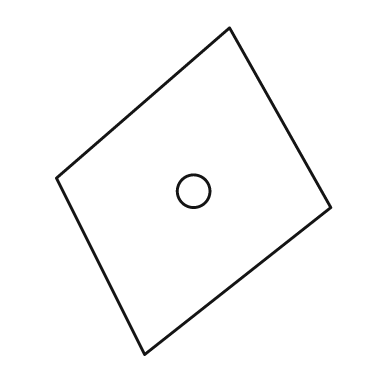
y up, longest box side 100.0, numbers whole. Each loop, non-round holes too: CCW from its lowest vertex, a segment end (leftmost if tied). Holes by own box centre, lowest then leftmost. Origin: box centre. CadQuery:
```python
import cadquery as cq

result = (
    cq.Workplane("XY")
    .moveTo(-15.0, -50.0)
    .lineTo(42.0, -5.0)
    .lineTo(11.0, 50.0)
    .lineTo(-42.0, 4.0)
    .close()
    .moveTo(0.0, 0.0)
    .circle(5.0)
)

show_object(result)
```